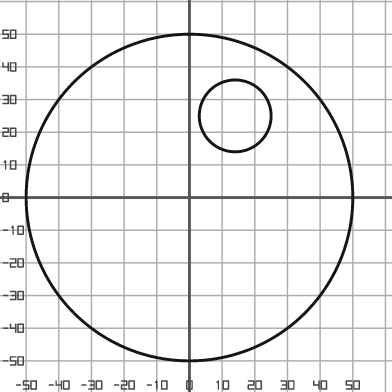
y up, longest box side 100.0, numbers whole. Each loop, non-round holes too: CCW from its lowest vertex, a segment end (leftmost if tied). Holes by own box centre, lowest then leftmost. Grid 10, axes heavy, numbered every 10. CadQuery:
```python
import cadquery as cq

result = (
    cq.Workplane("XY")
    .moveTo(0.0, 0.0)
    .circle(50.0)
    .moveTo(14.0, 25.0)
    .circle(11.0)
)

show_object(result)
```